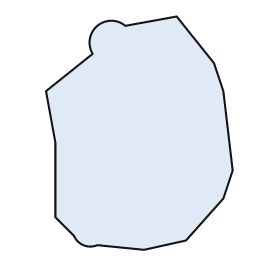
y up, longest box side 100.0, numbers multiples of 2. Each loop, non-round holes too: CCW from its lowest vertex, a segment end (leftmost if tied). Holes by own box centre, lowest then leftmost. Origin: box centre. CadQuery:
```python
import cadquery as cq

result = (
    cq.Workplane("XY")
    .moveTo(2.0, -50.0)
    .lineTo(20.0, -46.0)
    .lineTo(36.0, -28.0)
    .lineTo(40.0, -16.0)
    .lineTo(36.0, 18.0)
    .lineTo(32.0, 30.0)
    .lineTo(16.0, 50.0)
    .lineTo(-6.0, 46.0)
    .threePointArc((-18.0, 46.0), (-20.0, 34.0))
    .lineTo(-40.0, 18.0)
    .lineTo(-36.0, -4.0)
    .lineTo(-36.0, -36.0)
    .lineTo(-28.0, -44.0)
    .threePointArc((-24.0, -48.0), (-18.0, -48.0))
    .close()
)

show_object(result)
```